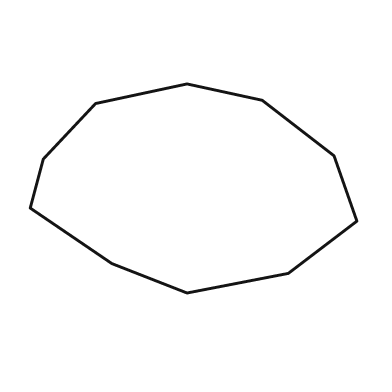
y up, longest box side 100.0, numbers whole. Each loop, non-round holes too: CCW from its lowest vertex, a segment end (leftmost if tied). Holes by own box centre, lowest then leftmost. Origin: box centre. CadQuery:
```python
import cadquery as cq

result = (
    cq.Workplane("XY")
    .moveTo(-2.0, -32.0)
    .lineTo(29.0, -26.0)
    .lineTo(50.0, -10.0)
    .lineTo(43.0, 10.0)
    .lineTo(21.0, 27.0)
    .lineTo(-2.0, 32.0)
    .lineTo(-30.0, 26.0)
    .lineTo(-46.0, 9.0)
    .lineTo(-50.0, -6.0)
    .lineTo(-25.0, -23.0)
    .close()
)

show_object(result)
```